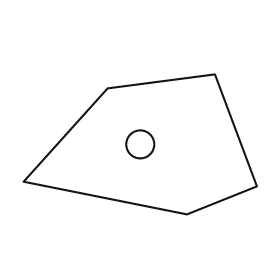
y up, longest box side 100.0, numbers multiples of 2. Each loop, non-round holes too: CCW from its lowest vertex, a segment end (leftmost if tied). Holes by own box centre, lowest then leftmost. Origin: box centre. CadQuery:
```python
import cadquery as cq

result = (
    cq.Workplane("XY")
    .moveTo(20.0, -30.0)
    .lineTo(50.0, -18.0)
    .lineTo(32.0, 30.0)
    .lineTo(-14.0, 24.0)
    .lineTo(-50.0, -16.0)
    .close()
    .moveTo(0.0, 0.0)
    .circle(6.0)
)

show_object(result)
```